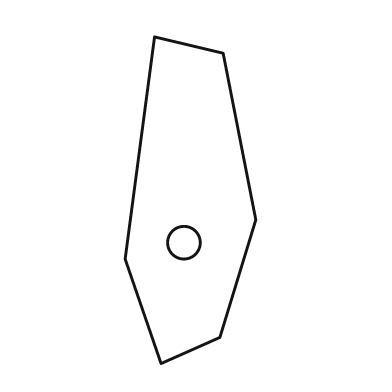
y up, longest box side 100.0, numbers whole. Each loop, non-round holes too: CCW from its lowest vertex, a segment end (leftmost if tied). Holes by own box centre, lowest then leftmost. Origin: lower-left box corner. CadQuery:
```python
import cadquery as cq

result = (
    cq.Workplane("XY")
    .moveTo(11.0, 0.0)
    .lineTo(29.0, 8.0)
    .lineTo(40.0, 44.0)
    .lineTo(30.0, 95.0)
    .lineTo(9.0, 100.0)
    .lineTo(0.0, 32.0)
    .close()
    .moveTo(18.0, 37.0)
    .circle(5.0)
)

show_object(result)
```